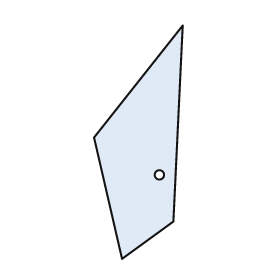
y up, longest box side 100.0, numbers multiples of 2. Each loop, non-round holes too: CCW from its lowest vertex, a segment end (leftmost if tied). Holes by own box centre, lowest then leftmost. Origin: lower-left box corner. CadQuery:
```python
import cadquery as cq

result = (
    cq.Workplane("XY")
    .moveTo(12.0, 0.0)
    .lineTo(34.0, 16.0)
    .lineTo(38.0, 100.0)
    .lineTo(0.0, 52.0)
    .close()
    .moveTo(28.0, 36.0)
    .circle(2.0)
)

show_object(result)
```